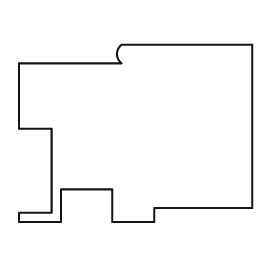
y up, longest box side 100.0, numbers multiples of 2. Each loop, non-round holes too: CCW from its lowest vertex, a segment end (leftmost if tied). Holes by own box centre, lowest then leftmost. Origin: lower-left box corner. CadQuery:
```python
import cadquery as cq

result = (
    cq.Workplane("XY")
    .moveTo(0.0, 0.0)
    .lineTo(18.0, 0.0)
    .lineTo(18.0, 14.0)
    .lineTo(40.0, 14.0)
    .lineTo(40.0, 0.0)
    .lineTo(58.0, 0.0)
    .lineTo(58.0, 6.0)
    .lineTo(100.0, 6.0)
    .lineTo(100.0, 76.0)
    .lineTo(44.0, 76.0)
    .threePointArc((42.0, 72.0), (44.0, 68.0))
    .lineTo(0.0, 68.0)
    .lineTo(0.0, 40.0)
    .lineTo(14.0, 40.0)
    .lineTo(14.0, 4.0)
    .lineTo(0.0, 4.0)
    .close()
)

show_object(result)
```